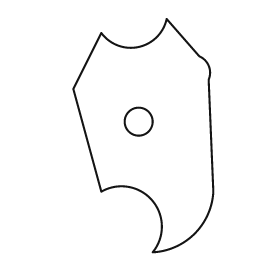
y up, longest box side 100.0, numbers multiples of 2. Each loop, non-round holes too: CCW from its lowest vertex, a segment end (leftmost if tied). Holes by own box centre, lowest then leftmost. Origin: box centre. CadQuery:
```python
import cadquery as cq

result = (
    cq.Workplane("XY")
    .moveTo(4.0, -50.0)
    .threePointArc((22.0, -42.0), (30.0, -24.0))
    .lineTo(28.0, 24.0)
    .threePointArc((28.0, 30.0), (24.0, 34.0))
    .lineTo(10.0, 50.0)
    .threePointArc((-2.0, 38.0), (-18.0, 44.0))
    .lineTo(-30.0, 20.0)
    .lineTo(-18.0, -24.0)
    .threePointArc((4.0, -28.0), (4.0, -50.0))
    .close()
    .moveTo(-2.0, 6.0)
    .circle(6.0)
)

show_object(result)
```